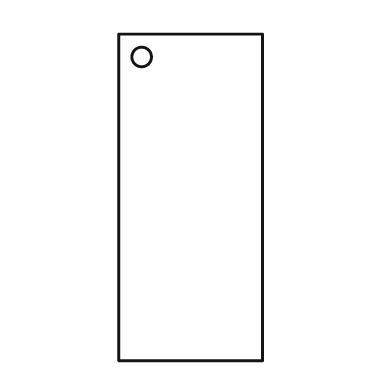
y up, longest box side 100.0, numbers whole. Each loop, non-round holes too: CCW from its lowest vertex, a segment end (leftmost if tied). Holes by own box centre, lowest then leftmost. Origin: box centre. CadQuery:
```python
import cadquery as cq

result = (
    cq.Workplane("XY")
    .moveTo(-22.0, -50.0)
    .lineTo(22.0, -50.0)
    .lineTo(22.0, 50.0)
    .lineTo(-22.0, 50.0)
    .close()
    .moveTo(-15.0, 43.0)
    .circle(3.0)
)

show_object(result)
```